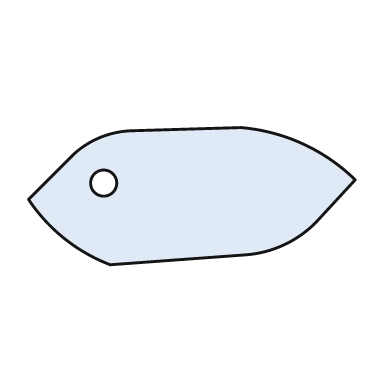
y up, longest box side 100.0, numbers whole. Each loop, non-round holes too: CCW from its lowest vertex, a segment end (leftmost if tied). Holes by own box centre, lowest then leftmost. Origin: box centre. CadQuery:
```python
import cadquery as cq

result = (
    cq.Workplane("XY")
    .moveTo(-25.0, -21.0)
    .lineTo(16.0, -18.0)
    .threePointArc((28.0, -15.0), (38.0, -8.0))
    .lineTo(50.0, 5.0)
    .threePointArc((34.0, 16.0), (15.0, 21.0))
    .lineTo(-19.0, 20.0)
    .threePointArc((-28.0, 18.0), (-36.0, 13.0))
    .lineTo(-50.0, -1.0)
    .threePointArc((-39.0, -13.0), (-25.0, -21.0))
    .close()
    .moveTo(-27.0, 4.0)
    .circle(4.0)
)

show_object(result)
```